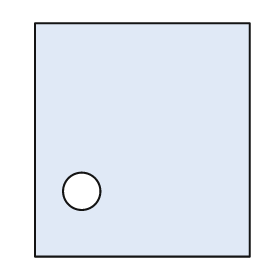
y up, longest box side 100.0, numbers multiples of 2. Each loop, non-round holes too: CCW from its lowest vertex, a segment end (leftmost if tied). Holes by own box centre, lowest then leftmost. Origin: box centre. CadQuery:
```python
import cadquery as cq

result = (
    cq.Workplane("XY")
    .moveTo(-46.0, -50.0)
    .lineTo(46.0, -50.0)
    .lineTo(46.0, 50.0)
    .lineTo(-46.0, 50.0)
    .close()
    .moveTo(-26.0, -22.0)
    .circle(8.0)
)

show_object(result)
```